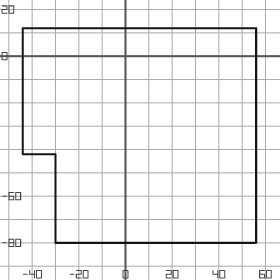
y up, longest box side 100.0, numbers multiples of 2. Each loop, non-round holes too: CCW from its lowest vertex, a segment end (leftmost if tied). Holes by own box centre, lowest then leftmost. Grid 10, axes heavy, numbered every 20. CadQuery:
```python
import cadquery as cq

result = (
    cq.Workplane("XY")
    .moveTo(-30.0, -80.0)
    .lineTo(56.0, -80.0)
    .lineTo(56.0, 12.0)
    .lineTo(-44.0, 12.0)
    .lineTo(-44.0, -42.0)
    .lineTo(-30.0, -42.0)
    .close()
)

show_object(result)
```